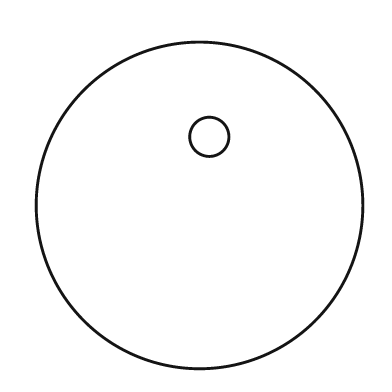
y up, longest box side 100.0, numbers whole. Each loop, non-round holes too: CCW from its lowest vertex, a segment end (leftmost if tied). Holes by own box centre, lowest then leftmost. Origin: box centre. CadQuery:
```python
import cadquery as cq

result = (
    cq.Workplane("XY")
    .moveTo(0.0, 0.0)
    .circle(50.0)
    .moveTo(3.0, 21.0)
    .circle(6.0)
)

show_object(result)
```